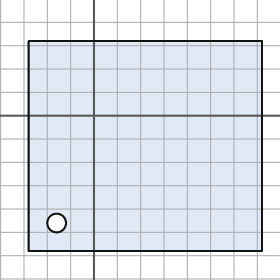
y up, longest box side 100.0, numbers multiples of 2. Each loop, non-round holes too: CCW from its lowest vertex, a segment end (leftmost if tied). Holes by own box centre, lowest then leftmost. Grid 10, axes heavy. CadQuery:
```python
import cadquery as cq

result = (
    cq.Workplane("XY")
    .moveTo(-28.0, -58.0)
    .lineTo(72.0, -58.0)
    .lineTo(72.0, 32.0)
    .lineTo(-28.0, 32.0)
    .close()
    .moveTo(-16.0, -46.0)
    .circle(4.0)
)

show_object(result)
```